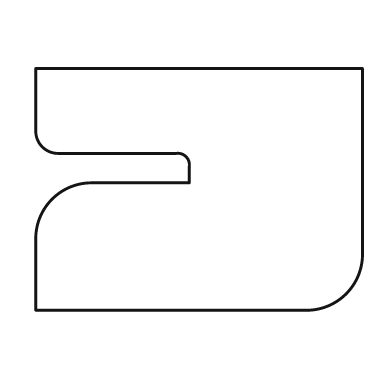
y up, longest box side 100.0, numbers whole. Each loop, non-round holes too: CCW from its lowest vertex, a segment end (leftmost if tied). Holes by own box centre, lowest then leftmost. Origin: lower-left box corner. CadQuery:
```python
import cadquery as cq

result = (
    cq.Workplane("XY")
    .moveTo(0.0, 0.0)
    .lineTo(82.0, 0.0)
    .threePointArc((95.0, 5.0), (100.0, 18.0))
    .lineTo(100.0, 74.0)
    .lineTo(0.0, 74.0)
    .lineTo(0.0, 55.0)
    .threePointArc((2.0, 50.0), (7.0, 48.0))
    .lineTo(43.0, 48.0)
    .threePointArc((46.0, 47.0), (47.0, 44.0))
    .lineTo(47.0, 39.0)
    .lineTo(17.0, 39.0)
    .threePointArc((5.0, 34.0), (0.0, 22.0))
    .close()
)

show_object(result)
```